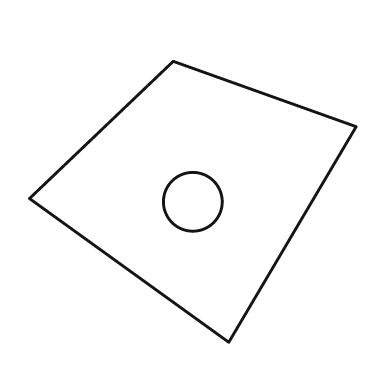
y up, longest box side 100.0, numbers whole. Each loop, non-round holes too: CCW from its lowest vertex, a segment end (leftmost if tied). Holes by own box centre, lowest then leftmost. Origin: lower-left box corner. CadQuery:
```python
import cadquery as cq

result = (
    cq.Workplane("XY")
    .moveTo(61.0, 0.0)
    .lineTo(100.0, 66.0)
    .lineTo(44.0, 86.0)
    .lineTo(0.0, 44.0)
    .close()
    .moveTo(50.0, 43.0)
    .circle(9.0)
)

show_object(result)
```